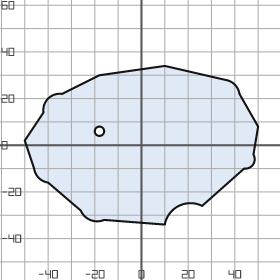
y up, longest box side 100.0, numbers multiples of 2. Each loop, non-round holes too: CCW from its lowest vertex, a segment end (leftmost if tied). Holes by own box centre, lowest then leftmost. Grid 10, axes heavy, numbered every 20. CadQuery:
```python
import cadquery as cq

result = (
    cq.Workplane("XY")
    .moveTo(10.0, -34.0)
    .threePointArc((16.0, -26.0), (26.0, -26.0))
    .lineTo(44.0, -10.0)
    .threePointArc((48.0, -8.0), (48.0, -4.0))
    .lineTo(50.0, 8.0)
    .lineTo(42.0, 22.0)
    .threePointArc((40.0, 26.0), (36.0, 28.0))
    .lineTo(10.0, 34.0)
    .lineTo(-18.0, 30.0)
    .lineTo(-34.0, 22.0)
    .threePointArc((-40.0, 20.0), (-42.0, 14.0))
    .lineTo(-50.0, 2.0)
    .lineTo(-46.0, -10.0)
    .threePointArc((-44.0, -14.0), (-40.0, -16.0))
    .lineTo(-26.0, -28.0)
    .threePointArc((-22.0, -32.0), (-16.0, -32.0))
    .close()
    .moveTo(-18.0, 6.0)
    .circle(2.0)
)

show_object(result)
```